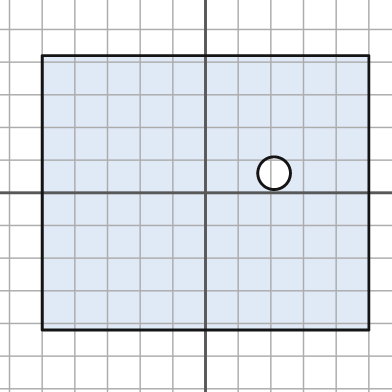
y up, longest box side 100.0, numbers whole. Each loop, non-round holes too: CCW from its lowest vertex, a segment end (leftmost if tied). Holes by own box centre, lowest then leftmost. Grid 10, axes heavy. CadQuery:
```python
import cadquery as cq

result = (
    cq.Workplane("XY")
    .moveTo(-50.0, -42.0)
    .lineTo(50.0, -42.0)
    .lineTo(50.0, 42.0)
    .lineTo(-50.0, 42.0)
    .close()
    .moveTo(21.0, 6.0)
    .circle(5.0)
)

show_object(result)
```